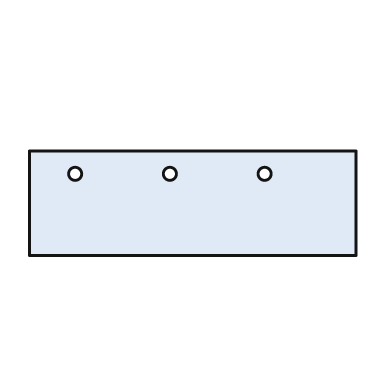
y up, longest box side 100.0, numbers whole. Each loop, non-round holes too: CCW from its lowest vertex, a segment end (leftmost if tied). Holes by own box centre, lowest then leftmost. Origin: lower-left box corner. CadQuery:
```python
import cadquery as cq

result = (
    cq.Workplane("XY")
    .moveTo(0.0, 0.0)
    .lineTo(100.0, 0.0)
    .lineTo(100.0, 32.0)
    .lineTo(0.0, 32.0)
    .close()
    .moveTo(14.0, 25.0)
    .circle(2.0)
    .moveTo(43.0, 25.0)
    .circle(2.0)
    .moveTo(72.0, 25.0)
    .circle(2.0)
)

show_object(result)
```